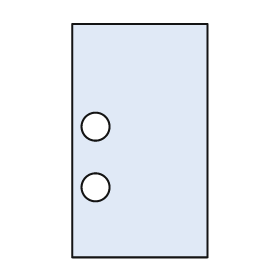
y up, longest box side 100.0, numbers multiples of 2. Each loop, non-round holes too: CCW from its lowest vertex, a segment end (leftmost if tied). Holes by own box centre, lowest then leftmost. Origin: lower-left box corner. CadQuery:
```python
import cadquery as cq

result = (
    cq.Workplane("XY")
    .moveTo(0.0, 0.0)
    .lineTo(58.0, 0.0)
    .lineTo(58.0, 100.0)
    .lineTo(0.0, 100.0)
    .close()
    .moveTo(10.0, 30.0)
    .circle(6.0)
    .moveTo(10.0, 56.0)
    .circle(6.0)
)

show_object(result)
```